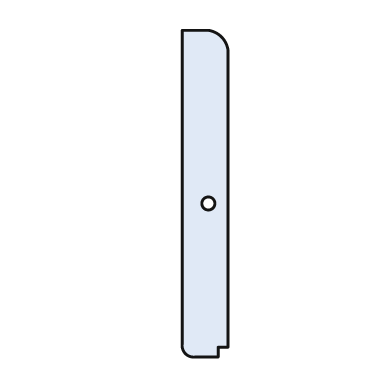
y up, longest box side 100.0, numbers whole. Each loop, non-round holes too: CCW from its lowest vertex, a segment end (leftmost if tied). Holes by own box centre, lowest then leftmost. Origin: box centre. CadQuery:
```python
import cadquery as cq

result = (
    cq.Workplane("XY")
    .moveTo(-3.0, -50.0)
    .lineTo(4.0, -50.0)
    .lineTo(4.0, -47.0)
    .lineTo(7.0, -47.0)
    .lineTo(7.0, 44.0)
    .threePointArc((5.0, 48.0), (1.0, 50.0))
    .lineTo(-7.0, 50.0)
    .lineTo(-7.0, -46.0)
    .threePointArc((-6.0, -49.0), (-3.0, -50.0))
    .close()
    .moveTo(1.0, -3.0)
    .circle(2.0)
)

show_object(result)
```